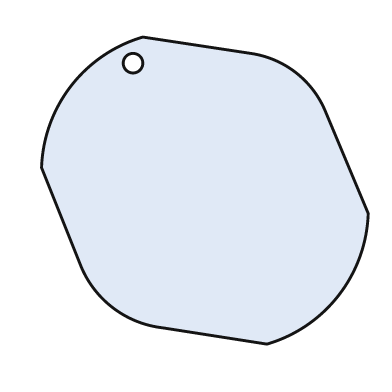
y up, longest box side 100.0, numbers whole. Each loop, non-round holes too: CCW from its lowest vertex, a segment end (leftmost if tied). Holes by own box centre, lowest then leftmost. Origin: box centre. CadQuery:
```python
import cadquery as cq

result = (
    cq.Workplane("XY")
    .moveTo(19.0, -47.0)
    .threePointArc((41.0, -32.0), (50.0, -7.0))
    .lineTo(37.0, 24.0)
    .threePointArc((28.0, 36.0), (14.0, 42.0))
    .lineTo(-19.0, 47.0)
    .threePointArc((-41.0, 32.0), (-50.0, 7.0))
    .lineTo(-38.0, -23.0)
    .threePointArc((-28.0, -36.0), (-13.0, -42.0))
    .close()
    .moveTo(-22.0, 39.0)
    .circle(3.0)
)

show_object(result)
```